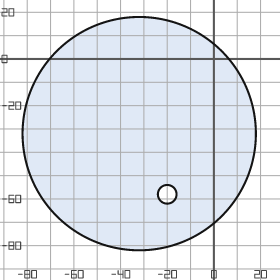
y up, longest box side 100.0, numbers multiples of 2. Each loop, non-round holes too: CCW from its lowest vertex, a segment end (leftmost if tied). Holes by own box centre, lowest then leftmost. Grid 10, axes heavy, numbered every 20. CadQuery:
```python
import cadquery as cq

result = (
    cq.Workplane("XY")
    .moveTo(-32.0, -32.0)
    .circle(50.0)
    .moveTo(-20.0, -58.0)
    .circle(4.0)
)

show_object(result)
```